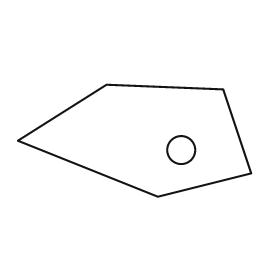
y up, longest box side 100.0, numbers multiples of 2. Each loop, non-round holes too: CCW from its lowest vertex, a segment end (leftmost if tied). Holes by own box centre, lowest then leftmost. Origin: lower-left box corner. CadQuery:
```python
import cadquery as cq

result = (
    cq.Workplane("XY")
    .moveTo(60.0, 0.0)
    .lineTo(100.0, 10.0)
    .lineTo(88.0, 46.0)
    .lineTo(38.0, 48.0)
    .lineTo(0.0, 24.0)
    .close()
    .moveTo(70.0, 20.0)
    .circle(6.0)
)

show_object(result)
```